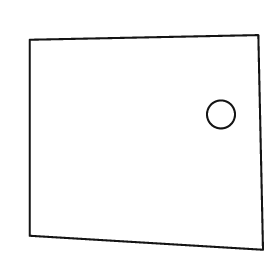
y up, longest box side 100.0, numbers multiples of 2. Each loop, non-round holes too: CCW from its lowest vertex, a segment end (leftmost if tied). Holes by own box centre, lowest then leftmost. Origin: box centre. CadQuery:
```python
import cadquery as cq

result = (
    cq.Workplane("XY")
    .moveTo(50.0, -46.0)
    .lineTo(48.0, 46.0)
    .lineTo(-50.0, 44.0)
    .lineTo(-50.0, -40.0)
    .close()
    .moveTo(32.0, 12.0)
    .circle(6.0)
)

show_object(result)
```